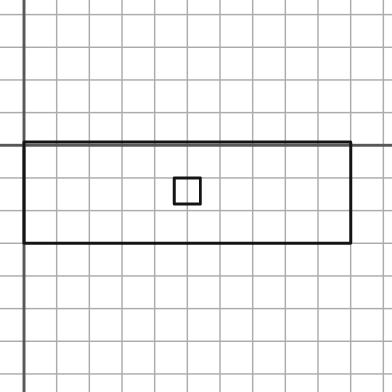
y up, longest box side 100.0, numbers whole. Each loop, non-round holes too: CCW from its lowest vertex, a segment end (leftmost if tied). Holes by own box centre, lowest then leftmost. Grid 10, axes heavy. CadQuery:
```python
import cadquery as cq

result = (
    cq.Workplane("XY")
    .moveTo(0.0, -30.0)
    .lineTo(100.0, -30.0)
    .lineTo(100.0, 1.0)
    .lineTo(0.0, 1.0)
    .close()
    .moveTo(46.0, -18.0)
    .lineTo(54.0, -18.0)
    .lineTo(54.0, -10.0)
    .lineTo(46.0, -10.0)
    .close()
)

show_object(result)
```